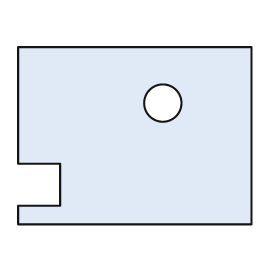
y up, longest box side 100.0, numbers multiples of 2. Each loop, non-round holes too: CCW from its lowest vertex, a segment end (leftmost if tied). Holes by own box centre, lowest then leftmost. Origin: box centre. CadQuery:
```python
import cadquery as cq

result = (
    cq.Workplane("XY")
    .moveTo(-50.0, -38.0)
    .lineTo(50.0, -38.0)
    .lineTo(50.0, 38.0)
    .lineTo(-50.0, 38.0)
    .lineTo(-50.0, -12.0)
    .lineTo(-32.0, -12.0)
    .lineTo(-32.0, -30.0)
    .lineTo(-50.0, -30.0)
    .close()
    .moveTo(12.0, 14.0)
    .circle(8.0)
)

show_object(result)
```